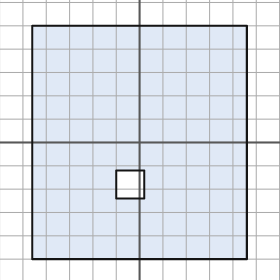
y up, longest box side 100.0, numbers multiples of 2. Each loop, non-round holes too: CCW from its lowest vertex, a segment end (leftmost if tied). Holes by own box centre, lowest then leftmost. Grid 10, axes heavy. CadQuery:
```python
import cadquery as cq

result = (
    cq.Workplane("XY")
    .moveTo(-46.0, -50.0)
    .lineTo(46.0, -50.0)
    .lineTo(46.0, 50.0)
    .lineTo(-46.0, 50.0)
    .close()
    .moveTo(-10.0, -24.0)
    .lineTo(2.0, -24.0)
    .lineTo(2.0, -12.0)
    .lineTo(-10.0, -12.0)
    .close()
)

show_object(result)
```